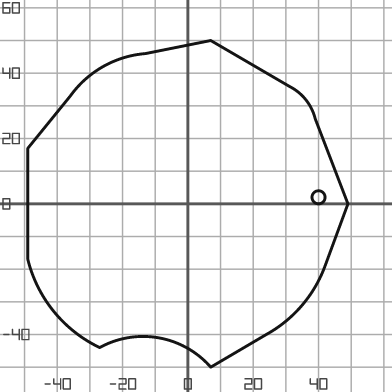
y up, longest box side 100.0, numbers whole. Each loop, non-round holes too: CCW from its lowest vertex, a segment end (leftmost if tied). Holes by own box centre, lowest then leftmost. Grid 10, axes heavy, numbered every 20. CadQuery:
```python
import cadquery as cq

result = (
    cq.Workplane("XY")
    .moveTo(7.0, -50.0)
    .lineTo(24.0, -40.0)
    .threePointArc((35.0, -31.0), (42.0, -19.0))
    .lineTo(49.0, 0.0)
    .lineTo(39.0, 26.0)
    .threePointArc((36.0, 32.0), (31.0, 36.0))
    .lineTo(7.0, 50.0)
    .lineTo(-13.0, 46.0)
    .threePointArc((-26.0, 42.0), (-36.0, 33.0))
    .lineTo(-49.0, 17.0)
    .lineTo(-49.0, -17.0)
    .threePointArc((-41.0, -33.0), (-27.0, -44.0))
    .threePointArc((-9.0, -41.0), (7.0, -50.0))
    .close()
    .moveTo(40.0, 2.0)
    .circle(2.0)
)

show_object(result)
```